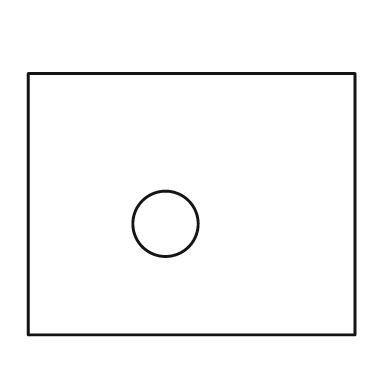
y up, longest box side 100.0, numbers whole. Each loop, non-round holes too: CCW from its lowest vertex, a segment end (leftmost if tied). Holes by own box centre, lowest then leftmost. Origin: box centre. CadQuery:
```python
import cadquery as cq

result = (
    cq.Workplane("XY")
    .moveTo(-50.0, -40.0)
    .lineTo(50.0, -40.0)
    .lineTo(50.0, 40.0)
    .lineTo(-50.0, 40.0)
    .close()
    .moveTo(-8.0, -6.0)
    .circle(10.0)
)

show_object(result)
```